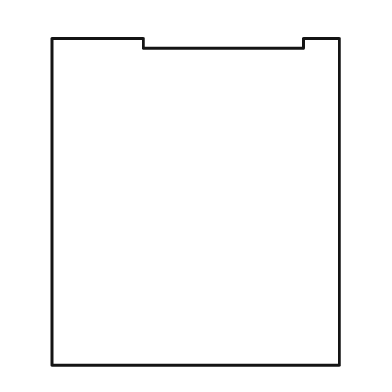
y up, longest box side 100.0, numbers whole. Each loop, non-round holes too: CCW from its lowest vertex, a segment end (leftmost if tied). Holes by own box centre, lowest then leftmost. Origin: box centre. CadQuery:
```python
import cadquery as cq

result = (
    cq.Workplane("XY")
    .moveTo(-44.0, -50.0)
    .lineTo(44.0, -50.0)
    .lineTo(44.0, 50.0)
    .lineTo(33.0, 50.0)
    .lineTo(33.0, 47.0)
    .lineTo(-16.0, 47.0)
    .lineTo(-16.0, 50.0)
    .lineTo(-44.0, 50.0)
    .close()
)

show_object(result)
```